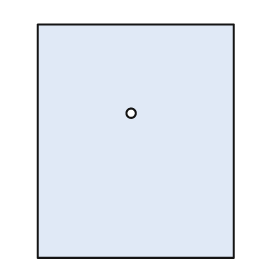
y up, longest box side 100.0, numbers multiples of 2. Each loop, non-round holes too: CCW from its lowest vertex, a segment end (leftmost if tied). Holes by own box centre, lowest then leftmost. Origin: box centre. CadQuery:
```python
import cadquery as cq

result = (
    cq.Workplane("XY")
    .moveTo(-42.0, -50.0)
    .lineTo(42.0, -50.0)
    .lineTo(42.0, 50.0)
    .lineTo(-42.0, 50.0)
    .close()
    .moveTo(-2.0, 12.0)
    .circle(2.0)
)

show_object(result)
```